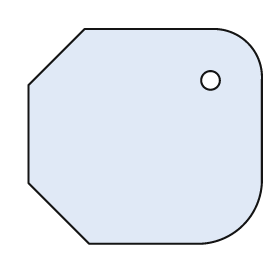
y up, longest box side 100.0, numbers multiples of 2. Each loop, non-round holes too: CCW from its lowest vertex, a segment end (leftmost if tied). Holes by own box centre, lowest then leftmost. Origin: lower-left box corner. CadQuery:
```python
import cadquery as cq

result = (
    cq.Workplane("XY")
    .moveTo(26.0, 0.0)
    .lineTo(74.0, 0.0)
    .threePointArc((92.0, 8.0), (100.0, 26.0))
    .lineTo(100.0, 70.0)
    .threePointArc((94.0, 86.0), (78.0, 92.0))
    .lineTo(24.0, 92.0)
    .lineTo(0.0, 68.0)
    .lineTo(0.0, 26.0)
    .close()
    .moveTo(78.0, 70.0)
    .circle(4.0)
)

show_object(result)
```